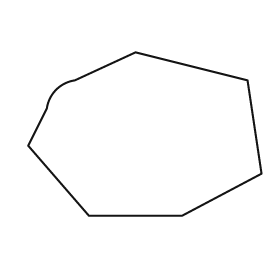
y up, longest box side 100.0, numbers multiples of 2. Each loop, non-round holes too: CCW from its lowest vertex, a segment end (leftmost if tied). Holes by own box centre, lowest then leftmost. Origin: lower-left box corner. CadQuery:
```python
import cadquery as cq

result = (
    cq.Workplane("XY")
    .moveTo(26.0, 0.0)
    .lineTo(66.0, 0.0)
    .lineTo(100.0, 18.0)
    .lineTo(94.0, 58.0)
    .lineTo(46.0, 70.0)
    .lineTo(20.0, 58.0)
    .threePointArc((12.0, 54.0), (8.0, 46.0))
    .lineTo(0.0, 30.0)
    .close()
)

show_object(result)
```